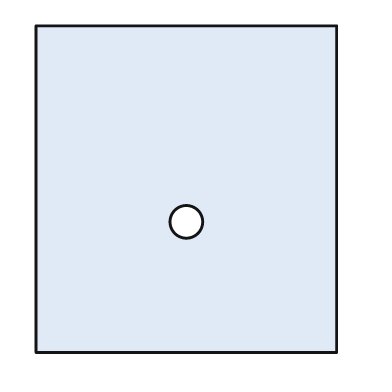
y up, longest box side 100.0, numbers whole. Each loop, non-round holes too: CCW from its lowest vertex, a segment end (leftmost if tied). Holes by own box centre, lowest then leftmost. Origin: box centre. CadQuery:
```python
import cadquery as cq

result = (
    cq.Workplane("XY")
    .moveTo(-46.0, -50.0)
    .lineTo(46.0, -50.0)
    .lineTo(46.0, 50.0)
    .lineTo(-46.0, 50.0)
    .close()
    .moveTo(0.0, -10.0)
    .circle(5.0)
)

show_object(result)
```